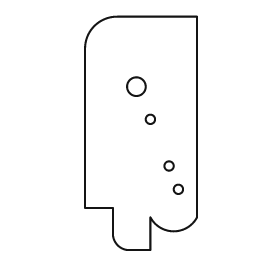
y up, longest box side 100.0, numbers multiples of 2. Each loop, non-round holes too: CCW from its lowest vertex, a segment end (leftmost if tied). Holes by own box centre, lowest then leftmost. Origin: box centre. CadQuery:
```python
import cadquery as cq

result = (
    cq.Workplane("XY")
    .moveTo(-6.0, -50.0)
    .lineTo(4.0, -50.0)
    .lineTo(4.0, -36.0)
    .threePointArc((14.0, -42.0), (24.0, -36.0))
    .lineTo(24.0, 50.0)
    .lineTo(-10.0, 50.0)
    .threePointArc((-20.0, 46.0), (-24.0, 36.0))
    .lineTo(-24.0, -32.0)
    .lineTo(-12.0, -32.0)
    .lineTo(-12.0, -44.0)
    .threePointArc((-10.0, -48.0), (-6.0, -50.0))
    .close()
    .moveTo(16.0, -24.0)
    .circle(2.0)
    .moveTo(12.0, -14.0)
    .circle(2.0)
    .moveTo(4.0, 6.0)
    .circle(2.0)
    .moveTo(-2.0, 20.0)
    .circle(4.0)
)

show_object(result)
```